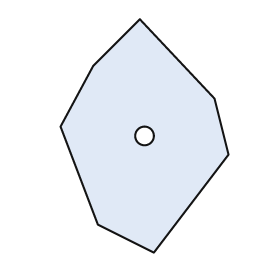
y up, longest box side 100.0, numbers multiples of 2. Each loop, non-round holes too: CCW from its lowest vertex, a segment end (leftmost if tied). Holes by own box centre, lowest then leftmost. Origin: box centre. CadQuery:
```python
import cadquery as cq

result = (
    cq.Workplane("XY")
    .moveTo(4.0, -50.0)
    .lineTo(36.0, -8.0)
    .lineTo(30.0, 16.0)
    .lineTo(-2.0, 50.0)
    .lineTo(-22.0, 30.0)
    .lineTo(-36.0, 4.0)
    .lineTo(-20.0, -38.0)
    .close()
    .moveTo(0.0, 0.0)
    .circle(4.0)
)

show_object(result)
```